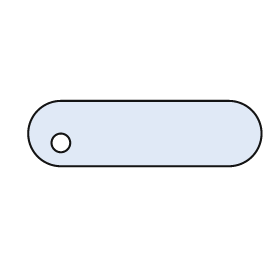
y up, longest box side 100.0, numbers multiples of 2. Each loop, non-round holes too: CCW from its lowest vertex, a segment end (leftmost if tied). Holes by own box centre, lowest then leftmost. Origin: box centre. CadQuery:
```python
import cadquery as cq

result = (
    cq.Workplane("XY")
    .moveTo(-36.0, -14.0)
    .lineTo(36.0, -14.0)
    .threePointArc((50.0, 0.0), (36.0, 14.0))
    .lineTo(-36.0, 14.0)
    .threePointArc((-50.0, 0.0), (-36.0, -14.0))
    .close()
    .moveTo(-36.0, -4.0)
    .circle(4.0)
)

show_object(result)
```